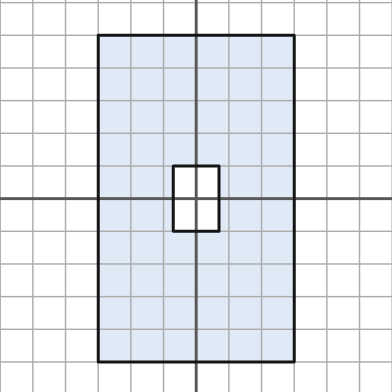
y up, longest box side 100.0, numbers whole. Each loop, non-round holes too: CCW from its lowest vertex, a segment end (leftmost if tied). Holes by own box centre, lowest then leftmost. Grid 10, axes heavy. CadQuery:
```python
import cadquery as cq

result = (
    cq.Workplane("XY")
    .moveTo(-30.0, -50.0)
    .lineTo(30.0, -50.0)
    .lineTo(30.0, 50.0)
    .lineTo(-30.0, 50.0)
    .close()
    .moveTo(-7.0, -10.0)
    .lineTo(7.0, -10.0)
    .lineTo(7.0, 10.0)
    .lineTo(-7.0, 10.0)
    .close()
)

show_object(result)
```